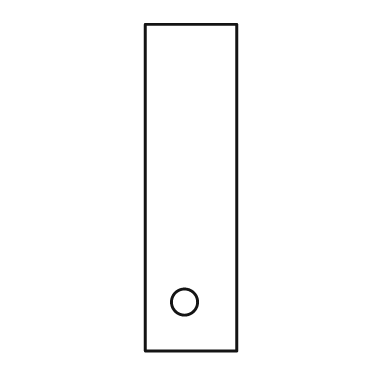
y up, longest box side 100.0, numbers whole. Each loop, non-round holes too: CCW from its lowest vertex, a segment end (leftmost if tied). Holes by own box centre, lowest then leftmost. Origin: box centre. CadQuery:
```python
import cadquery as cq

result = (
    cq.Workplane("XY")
    .moveTo(-14.0, -50.0)
    .lineTo(14.0, -50.0)
    .lineTo(14.0, 50.0)
    .lineTo(-14.0, 50.0)
    .close()
    .moveTo(-2.0, -35.0)
    .circle(4.0)
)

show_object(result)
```